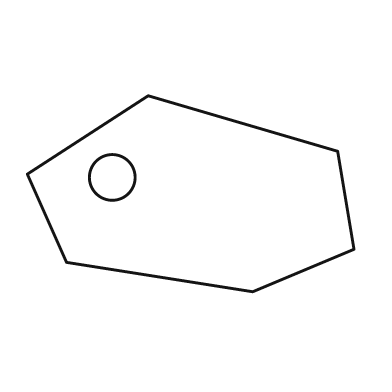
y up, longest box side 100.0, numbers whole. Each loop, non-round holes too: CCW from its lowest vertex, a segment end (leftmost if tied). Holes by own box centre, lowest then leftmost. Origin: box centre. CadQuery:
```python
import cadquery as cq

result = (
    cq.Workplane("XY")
    .moveTo(19.0, -30.0)
    .lineTo(50.0, -17.0)
    .lineTo(45.0, 13.0)
    .lineTo(-13.0, 30.0)
    .lineTo(-50.0, 6.0)
    .lineTo(-38.0, -21.0)
    .close()
    .moveTo(-24.0, 5.0)
    .circle(7.0)
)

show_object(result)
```